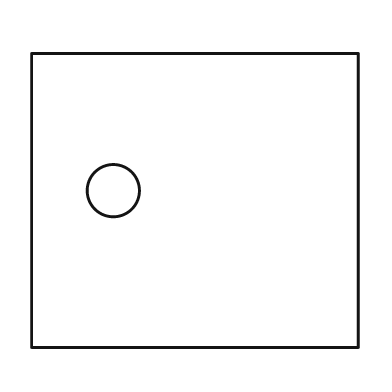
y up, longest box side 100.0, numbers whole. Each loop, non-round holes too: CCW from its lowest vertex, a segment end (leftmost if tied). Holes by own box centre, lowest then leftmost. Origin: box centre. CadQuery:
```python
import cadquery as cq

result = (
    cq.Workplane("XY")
    .moveTo(-50.0, -45.0)
    .lineTo(50.0, -45.0)
    .lineTo(50.0, 45.0)
    .lineTo(-50.0, 45.0)
    .close()
    .moveTo(-25.0, 3.0)
    .circle(8.0)
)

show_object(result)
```